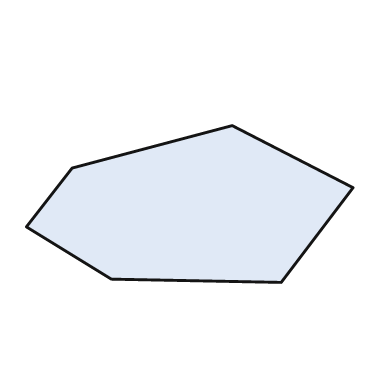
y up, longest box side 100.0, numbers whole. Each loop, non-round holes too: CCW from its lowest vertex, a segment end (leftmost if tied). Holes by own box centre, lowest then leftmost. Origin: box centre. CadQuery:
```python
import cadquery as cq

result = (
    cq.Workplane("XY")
    .moveTo(28.0, -24.0)
    .lineTo(50.0, 5.0)
    .lineTo(13.0, 24.0)
    .lineTo(-36.0, 11.0)
    .lineTo(-50.0, -7.0)
    .lineTo(-24.0, -23.0)
    .close()
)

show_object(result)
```